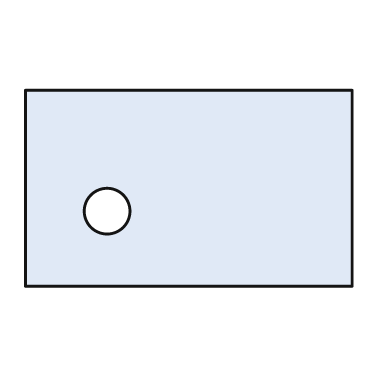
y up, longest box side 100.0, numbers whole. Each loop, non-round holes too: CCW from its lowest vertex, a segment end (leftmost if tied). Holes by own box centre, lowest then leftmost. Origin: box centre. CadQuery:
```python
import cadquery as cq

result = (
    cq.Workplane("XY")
    .moveTo(-50.0, -30.0)
    .lineTo(50.0, -30.0)
    .lineTo(50.0, 30.0)
    .lineTo(-50.0, 30.0)
    .close()
    .moveTo(-25.0, -7.0)
    .circle(7.0)
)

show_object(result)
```